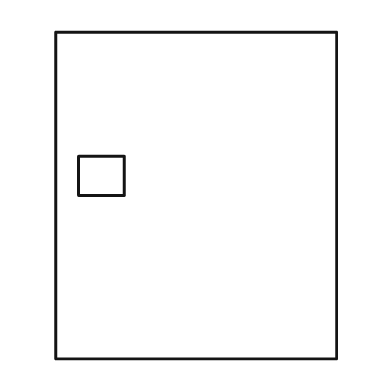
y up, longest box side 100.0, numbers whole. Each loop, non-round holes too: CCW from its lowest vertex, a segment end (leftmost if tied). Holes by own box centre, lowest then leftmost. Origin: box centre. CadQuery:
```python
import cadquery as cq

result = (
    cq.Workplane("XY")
    .moveTo(-43.0, -50.0)
    .lineTo(43.0, -50.0)
    .lineTo(43.0, 50.0)
    .lineTo(-43.0, 50.0)
    .close()
    .moveTo(-36.0, 0.0)
    .lineTo(-22.0, 0.0)
    .lineTo(-22.0, 12.0)
    .lineTo(-36.0, 12.0)
    .close()
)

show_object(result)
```